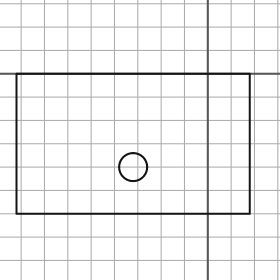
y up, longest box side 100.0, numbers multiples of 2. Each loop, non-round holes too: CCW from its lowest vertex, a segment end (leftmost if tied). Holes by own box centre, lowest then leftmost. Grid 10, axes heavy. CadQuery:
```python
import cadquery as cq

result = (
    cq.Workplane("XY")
    .moveTo(-82.0, -60.0)
    .lineTo(18.0, -60.0)
    .lineTo(18.0, 0.0)
    .lineTo(-82.0, 0.0)
    .close()
    .moveTo(-32.0, -40.0)
    .circle(6.0)
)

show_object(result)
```